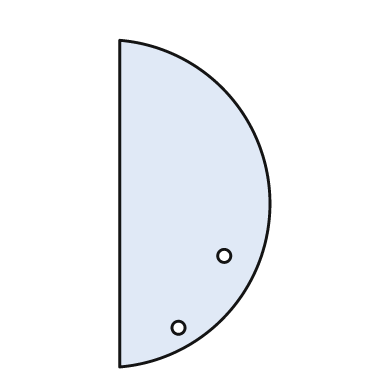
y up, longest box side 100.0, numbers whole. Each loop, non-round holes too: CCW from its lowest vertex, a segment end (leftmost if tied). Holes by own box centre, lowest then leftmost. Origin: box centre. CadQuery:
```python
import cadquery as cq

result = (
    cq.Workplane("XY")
    .moveTo(-23.0, -50.0)
    .threePointArc((23.0, 0.0), (-23.0, 50.0))
    .close()
    .moveTo(-5.0, -38.0)
    .circle(2.0)
    .moveTo(9.0, -16.0)
    .circle(2.0)
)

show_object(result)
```